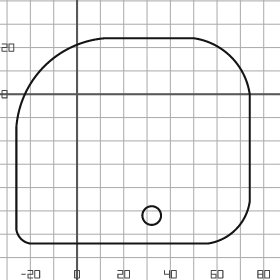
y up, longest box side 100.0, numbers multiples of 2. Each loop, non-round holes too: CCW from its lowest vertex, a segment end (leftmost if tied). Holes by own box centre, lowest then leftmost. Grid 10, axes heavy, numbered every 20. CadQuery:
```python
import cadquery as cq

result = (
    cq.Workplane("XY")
    .moveTo(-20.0, -64.0)
    .lineTo(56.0, -64.0)
    .threePointArc((68.0, -58.0), (74.0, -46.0))
    .lineTo(74.0, 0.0)
    .threePointArc((66.0, 16.0), (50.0, 24.0))
    .lineTo(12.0, 24.0)
    .threePointArc((-14.0, 12.0), (-26.0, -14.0))
    .lineTo(-26.0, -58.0)
    .threePointArc((-24.0, -62.0), (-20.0, -64.0))
    .close()
    .moveTo(32.0, -52.0)
    .circle(4.0)
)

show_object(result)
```